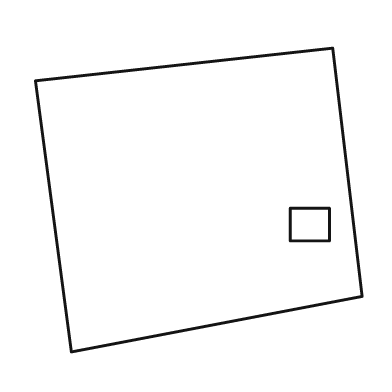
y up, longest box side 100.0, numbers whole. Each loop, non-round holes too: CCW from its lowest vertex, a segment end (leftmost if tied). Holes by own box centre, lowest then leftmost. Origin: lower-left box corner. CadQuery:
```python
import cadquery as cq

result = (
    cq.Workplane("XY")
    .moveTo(11.0, 0.0)
    .lineTo(100.0, 17.0)
    .lineTo(91.0, 93.0)
    .lineTo(0.0, 83.0)
    .close()
    .moveTo(78.0, 34.0)
    .lineTo(90.0, 34.0)
    .lineTo(90.0, 44.0)
    .lineTo(78.0, 44.0)
    .close()
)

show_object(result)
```